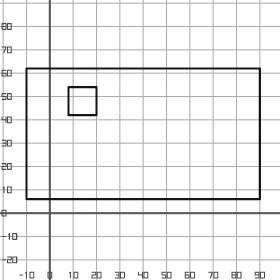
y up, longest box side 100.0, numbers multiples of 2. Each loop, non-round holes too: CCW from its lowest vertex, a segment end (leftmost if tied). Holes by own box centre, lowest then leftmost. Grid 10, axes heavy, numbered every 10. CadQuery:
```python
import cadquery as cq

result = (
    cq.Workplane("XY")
    .moveTo(-10.0, 6.0)
    .lineTo(90.0, 6.0)
    .lineTo(90.0, 62.0)
    .lineTo(-10.0, 62.0)
    .close()
    .moveTo(8.0, 42.0)
    .lineTo(20.0, 42.0)
    .lineTo(20.0, 54.0)
    .lineTo(8.0, 54.0)
    .close()
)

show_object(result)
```